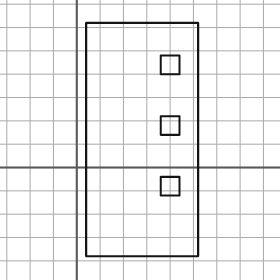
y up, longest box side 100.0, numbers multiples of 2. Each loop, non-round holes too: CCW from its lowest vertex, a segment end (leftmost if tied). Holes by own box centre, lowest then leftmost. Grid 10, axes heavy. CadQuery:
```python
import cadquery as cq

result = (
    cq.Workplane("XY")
    .moveTo(4.0, -38.0)
    .lineTo(52.0, -38.0)
    .lineTo(52.0, 62.0)
    .lineTo(4.0, 62.0)
    .close()
    .moveTo(36.0, -12.0)
    .lineTo(44.0, -12.0)
    .lineTo(44.0, -4.0)
    .lineTo(36.0, -4.0)
    .close()
    .moveTo(36.0, 14.0)
    .lineTo(44.0, 14.0)
    .lineTo(44.0, 22.0)
    .lineTo(36.0, 22.0)
    .close()
    .moveTo(36.0, 40.0)
    .lineTo(44.0, 40.0)
    .lineTo(44.0, 48.0)
    .lineTo(36.0, 48.0)
    .close()
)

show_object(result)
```